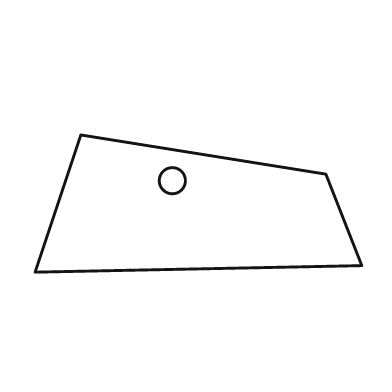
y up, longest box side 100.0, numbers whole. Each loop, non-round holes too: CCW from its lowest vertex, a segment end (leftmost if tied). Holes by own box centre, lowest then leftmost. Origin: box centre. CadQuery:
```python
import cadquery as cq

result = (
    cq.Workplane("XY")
    .moveTo(-50.0, -21.0)
    .lineTo(50.0, -19.0)
    .lineTo(39.0, 9.0)
    .lineTo(-36.0, 21.0)
    .close()
    .moveTo(-8.0, 7.0)
    .circle(4.0)
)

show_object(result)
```